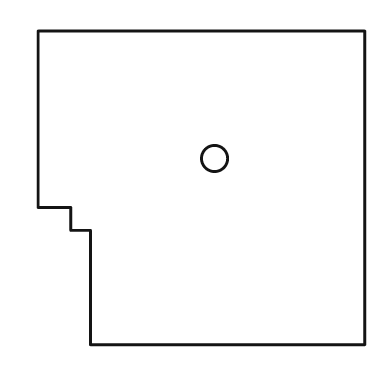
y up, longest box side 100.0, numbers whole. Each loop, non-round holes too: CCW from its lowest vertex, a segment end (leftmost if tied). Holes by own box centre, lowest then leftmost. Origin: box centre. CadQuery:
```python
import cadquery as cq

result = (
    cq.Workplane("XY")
    .moveTo(-34.0, -48.0)
    .lineTo(50.0, -48.0)
    .lineTo(50.0, 48.0)
    .lineTo(-50.0, 48.0)
    .lineTo(-50.0, -6.0)
    .lineTo(-40.0, -6.0)
    .lineTo(-40.0, -13.0)
    .lineTo(-34.0, -13.0)
    .close()
    .moveTo(4.0, 9.0)
    .circle(4.0)
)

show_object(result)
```